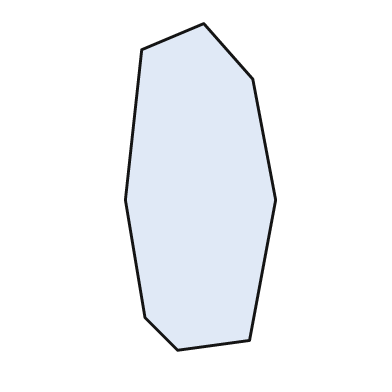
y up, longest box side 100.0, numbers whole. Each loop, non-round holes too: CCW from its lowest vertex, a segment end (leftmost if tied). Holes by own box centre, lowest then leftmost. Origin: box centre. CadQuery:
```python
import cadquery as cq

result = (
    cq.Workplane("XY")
    .moveTo(-7.0, -50.0)
    .lineTo(15.0, -47.0)
    .lineTo(23.0, -4.0)
    .lineTo(16.0, 33.0)
    .lineTo(1.0, 50.0)
    .lineTo(-18.0, 42.0)
    .lineTo(-23.0, -4.0)
    .lineTo(-17.0, -40.0)
    .close()
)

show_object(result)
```